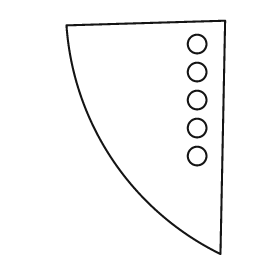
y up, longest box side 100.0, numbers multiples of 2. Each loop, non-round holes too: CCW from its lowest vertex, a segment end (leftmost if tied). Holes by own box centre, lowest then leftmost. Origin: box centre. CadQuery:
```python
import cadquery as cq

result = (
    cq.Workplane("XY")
    .moveTo(32.0, -50.0)
    .lineTo(34.0, 50.0)
    .lineTo(-34.0, 48.0)
    .threePointArc((-14.0, -10.0), (32.0, -50.0))
    .close()
    .moveTo(22.0, -8.0)
    .circle(4.0)
    .moveTo(22.0, 4.0)
    .circle(4.0)
    .moveTo(22.0, 16.0)
    .circle(4.0)
    .moveTo(22.0, 28.0)
    .circle(4.0)
    .moveTo(22.0, 40.0)
    .circle(4.0)
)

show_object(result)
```